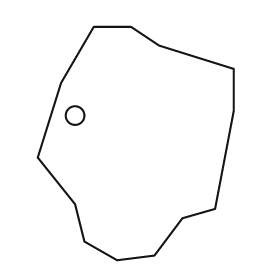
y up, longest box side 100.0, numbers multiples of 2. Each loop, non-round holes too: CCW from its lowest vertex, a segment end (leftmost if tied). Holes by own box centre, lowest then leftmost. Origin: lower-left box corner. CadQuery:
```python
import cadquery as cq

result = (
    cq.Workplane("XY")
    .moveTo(34.0, 0.0)
    .lineTo(50.0, 2.0)
    .lineTo(62.0, 18.0)
    .lineTo(76.0, 22.0)
    .lineTo(84.0, 64.0)
    .lineTo(84.0, 82.0)
    .lineTo(52.0, 92.0)
    .lineTo(40.0, 100.0)
    .lineTo(24.0, 100.0)
    .lineTo(10.0, 76.0)
    .lineTo(0.0, 44.0)
    .lineTo(16.0, 24.0)
    .lineTo(20.0, 8.0)
    .close()
    .moveTo(16.0, 62.0)
    .circle(4.0)
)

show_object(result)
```